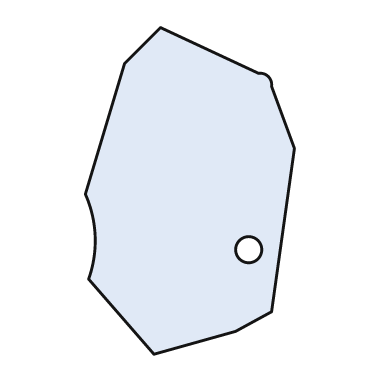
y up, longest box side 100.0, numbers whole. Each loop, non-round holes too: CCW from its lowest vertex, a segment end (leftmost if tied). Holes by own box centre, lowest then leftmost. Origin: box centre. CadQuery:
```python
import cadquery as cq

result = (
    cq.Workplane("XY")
    .moveTo(-11.0, -50.0)
    .lineTo(14.0, -43.0)
    .lineTo(25.0, -37.0)
    .lineTo(32.0, 13.0)
    .lineTo(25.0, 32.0)
    .threePointArc((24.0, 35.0), (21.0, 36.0))
    .lineTo(-9.0, 50.0)
    .lineTo(-20.0, 39.0)
    .lineTo(-32.0, -1.0)
    .threePointArc((-29.0, -14.0), (-31.0, -27.0))
    .close()
    .moveTo(18.0, -18.0)
    .circle(4.0)
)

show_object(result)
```